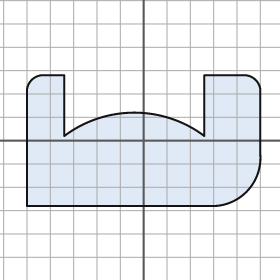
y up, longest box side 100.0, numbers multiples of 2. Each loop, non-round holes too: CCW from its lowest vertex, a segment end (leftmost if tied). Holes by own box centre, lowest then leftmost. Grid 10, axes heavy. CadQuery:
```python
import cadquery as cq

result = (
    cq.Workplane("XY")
    .moveTo(-50.0, -28.0)
    .lineTo(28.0, -28.0)
    .threePointArc((44.0, -22.0), (50.0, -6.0))
    .lineTo(50.0, 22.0)
    .threePointArc((48.0, 26.0), (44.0, 28.0))
    .lineTo(26.0, 28.0)
    .lineTo(26.0, 2.0)
    .threePointArc((-4.0, 12.0), (-34.0, 2.0))
    .lineTo(-34.0, 28.0)
    .lineTo(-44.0, 28.0)
    .threePointArc((-48.0, 26.0), (-50.0, 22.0))
    .close()
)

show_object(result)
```